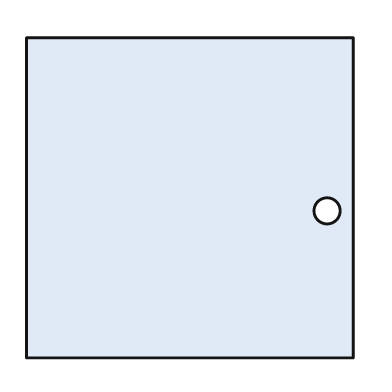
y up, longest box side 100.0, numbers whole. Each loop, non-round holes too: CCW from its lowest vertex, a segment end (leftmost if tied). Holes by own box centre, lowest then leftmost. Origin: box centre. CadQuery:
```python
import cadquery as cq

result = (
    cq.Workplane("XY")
    .moveTo(-50.0, -49.0)
    .lineTo(50.0, -49.0)
    .lineTo(50.0, 49.0)
    .lineTo(-50.0, 49.0)
    .close()
    .moveTo(42.0, -4.0)
    .circle(4.0)
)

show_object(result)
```